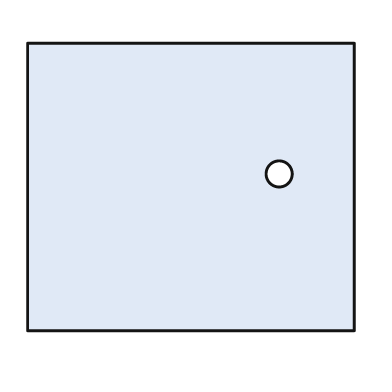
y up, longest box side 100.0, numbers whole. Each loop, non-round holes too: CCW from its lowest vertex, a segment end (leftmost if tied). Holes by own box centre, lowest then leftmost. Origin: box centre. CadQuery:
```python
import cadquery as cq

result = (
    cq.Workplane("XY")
    .moveTo(-50.0, -44.0)
    .lineTo(50.0, -44.0)
    .lineTo(50.0, 44.0)
    .lineTo(-50.0, 44.0)
    .close()
    .moveTo(27.0, 4.0)
    .circle(4.0)
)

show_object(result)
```